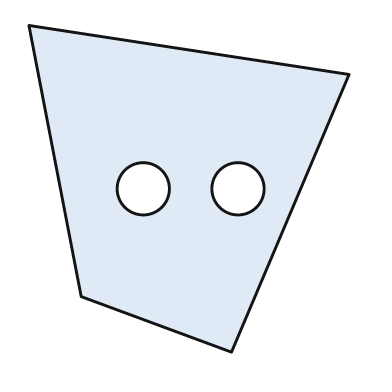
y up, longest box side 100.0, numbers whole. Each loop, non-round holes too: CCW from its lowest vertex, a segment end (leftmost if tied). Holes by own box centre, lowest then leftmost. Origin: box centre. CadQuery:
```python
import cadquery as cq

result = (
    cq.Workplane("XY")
    .moveTo(13.0, -50.0)
    .lineTo(49.0, 35.0)
    .lineTo(-49.0, 50.0)
    .lineTo(-33.0, -33.0)
    .close()
    .moveTo(-14.0, 0.0)
    .circle(8.0)
    .moveTo(15.0, 0.0)
    .circle(8.0)
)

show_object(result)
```